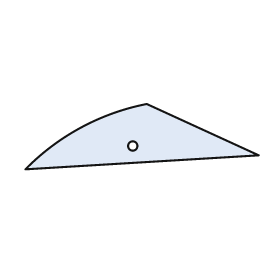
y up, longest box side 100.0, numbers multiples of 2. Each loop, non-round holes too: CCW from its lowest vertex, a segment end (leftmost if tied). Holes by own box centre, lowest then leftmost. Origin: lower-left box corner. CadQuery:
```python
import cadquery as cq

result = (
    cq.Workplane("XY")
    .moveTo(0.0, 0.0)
    .lineTo(100.0, 6.0)
    .lineTo(52.0, 28.0)
    .threePointArc((24.0, 18.0), (0.0, 0.0))
    .close()
    .moveTo(46.0, 10.0)
    .circle(2.0)
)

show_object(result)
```